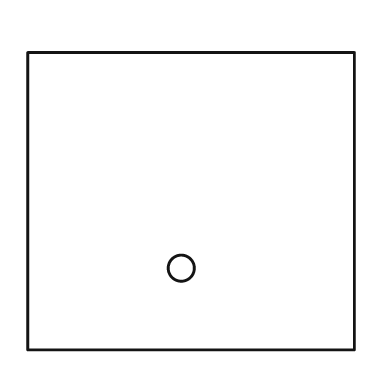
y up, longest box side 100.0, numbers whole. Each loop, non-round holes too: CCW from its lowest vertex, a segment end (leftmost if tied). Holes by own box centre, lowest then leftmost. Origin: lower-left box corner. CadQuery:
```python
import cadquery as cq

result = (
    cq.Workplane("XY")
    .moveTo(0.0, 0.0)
    .lineTo(100.0, 0.0)
    .lineTo(100.0, 91.0)
    .lineTo(0.0, 91.0)
    .close()
    .moveTo(47.0, 25.0)
    .circle(4.0)
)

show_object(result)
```